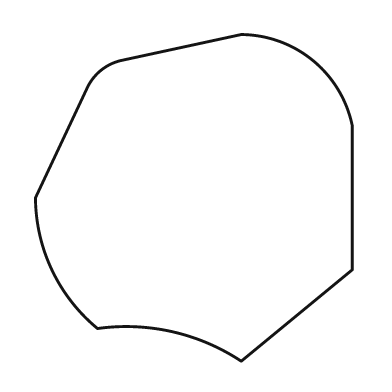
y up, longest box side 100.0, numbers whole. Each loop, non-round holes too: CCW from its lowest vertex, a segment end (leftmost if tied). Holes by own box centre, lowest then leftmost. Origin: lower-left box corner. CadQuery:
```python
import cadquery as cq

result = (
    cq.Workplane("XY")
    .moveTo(63.0, 0.0)
    .lineTo(97.0, 28.0)
    .lineTo(97.0, 72.0)
    .threePointArc((85.0, 92.0), (63.0, 100.0))
    .lineTo(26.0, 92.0)
    .threePointArc((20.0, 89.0), (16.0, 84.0))
    .lineTo(0.0, 50.0)
    .threePointArc((5.0, 28.0), (19.0, 10.0))
    .threePointArc((42.0, 9.0), (63.0, 0.0))
    .close()
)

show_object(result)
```